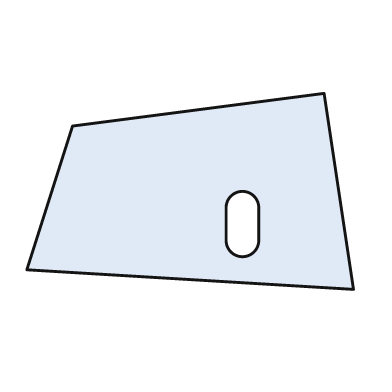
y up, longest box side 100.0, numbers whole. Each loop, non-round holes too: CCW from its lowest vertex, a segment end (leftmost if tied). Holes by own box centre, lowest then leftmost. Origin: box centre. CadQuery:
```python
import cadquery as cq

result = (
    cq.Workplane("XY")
    .moveTo(50.0, -30.0)
    .lineTo(41.0, 30.0)
    .lineTo(-36.0, 20.0)
    .lineTo(-50.0, -24.0)
    .close()
    .moveTo(11.0, -15.0)
    .threePointArc((16.0, -20.0), (21.0, -15.0))
    .lineTo(21.0, -5.0)
    .threePointArc((16.0, 0.0), (11.0, -5.0))
    .close()
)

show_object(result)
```